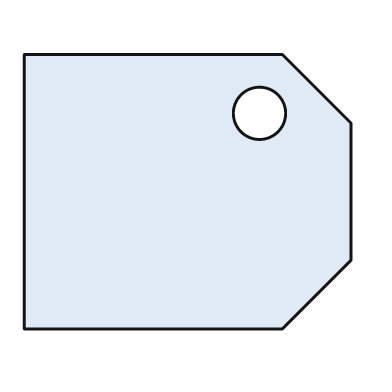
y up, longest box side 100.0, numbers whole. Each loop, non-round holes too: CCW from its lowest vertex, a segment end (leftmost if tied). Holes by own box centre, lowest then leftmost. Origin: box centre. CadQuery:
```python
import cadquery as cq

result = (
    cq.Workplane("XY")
    .moveTo(-50.0, -42.0)
    .lineTo(29.0, -42.0)
    .lineTo(50.0, -21.0)
    .lineTo(50.0, 21.0)
    .lineTo(29.0, 42.0)
    .lineTo(-50.0, 42.0)
    .close()
    .moveTo(22.0, 24.0)
    .circle(8.0)
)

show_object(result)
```